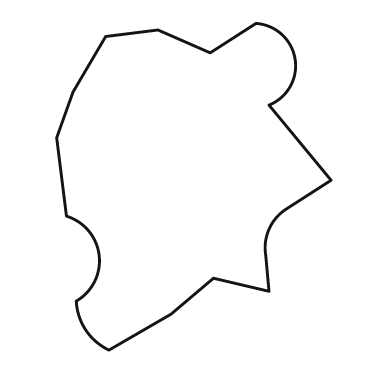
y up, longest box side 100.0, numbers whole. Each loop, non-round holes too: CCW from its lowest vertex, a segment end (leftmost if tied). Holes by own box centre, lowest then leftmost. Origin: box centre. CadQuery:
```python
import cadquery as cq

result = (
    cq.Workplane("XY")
    .moveTo(-26.0, -50.0)
    .lineTo(-7.0, -39.0)
    .lineTo(6.0, -28.0)
    .lineTo(23.0, -32.0)
    .lineTo(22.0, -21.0)
    .threePointArc((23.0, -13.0), (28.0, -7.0))
    .lineTo(42.0, 2.0)
    .lineTo(23.0, 25.0)
    .threePointArc((31.0, 39.0), (19.0, 50.0))
    .lineTo(5.0, 41.0)
    .lineTo(-11.0, 48.0)
    .lineTo(-27.0, 46.0)
    .lineTo(-37.0, 29.0)
    .lineTo(-42.0, 15.0)
    .lineTo(-39.0, -9.0)
    .threePointArc((-29.0, -21.0), (-36.0, -35.0))
    .threePointArc((-33.0, -44.0), (-26.0, -50.0))
    .close()
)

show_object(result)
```